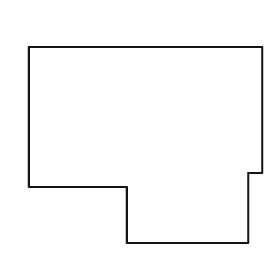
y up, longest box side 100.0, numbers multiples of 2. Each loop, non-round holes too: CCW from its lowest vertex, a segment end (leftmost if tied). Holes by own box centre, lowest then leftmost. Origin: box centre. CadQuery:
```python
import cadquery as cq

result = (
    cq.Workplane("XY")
    .moveTo(-8.0, -42.0)
    .lineTo(44.0, -42.0)
    .lineTo(44.0, -12.0)
    .lineTo(50.0, -12.0)
    .lineTo(50.0, 42.0)
    .lineTo(-50.0, 42.0)
    .lineTo(-50.0, -18.0)
    .lineTo(-8.0, -18.0)
    .close()
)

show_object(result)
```